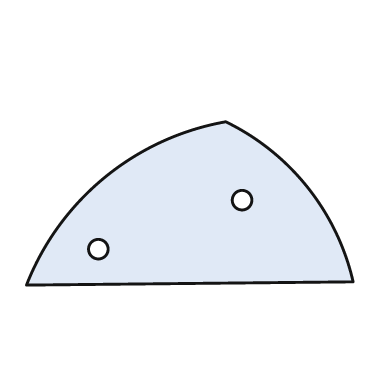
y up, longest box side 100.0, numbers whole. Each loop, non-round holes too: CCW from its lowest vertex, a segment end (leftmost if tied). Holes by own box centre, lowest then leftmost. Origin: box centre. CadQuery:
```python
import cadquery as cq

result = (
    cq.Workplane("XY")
    .moveTo(-50.0, -25.0)
    .lineTo(50.0, -24.0)
    .threePointArc((36.0, 5.0), (11.0, 25.0))
    .threePointArc((-26.0, 8.0), (-50.0, -25.0))
    .close()
    .moveTo(-28.0, -14.0)
    .circle(3.0)
    .moveTo(16.0, 1.0)
    .circle(3.0)
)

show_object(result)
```